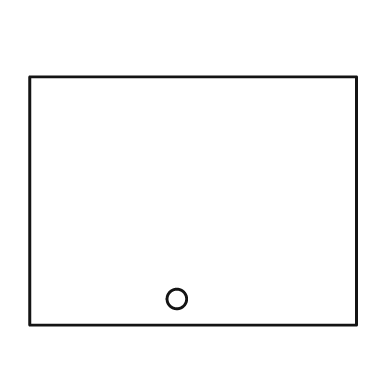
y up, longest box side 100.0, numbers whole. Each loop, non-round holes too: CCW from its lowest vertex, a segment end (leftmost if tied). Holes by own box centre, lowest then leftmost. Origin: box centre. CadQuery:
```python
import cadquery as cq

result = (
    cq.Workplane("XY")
    .moveTo(-50.0, -38.0)
    .lineTo(50.0, -38.0)
    .lineTo(50.0, 38.0)
    .lineTo(-50.0, 38.0)
    .close()
    .moveTo(-5.0, -30.0)
    .circle(3.0)
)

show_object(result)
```